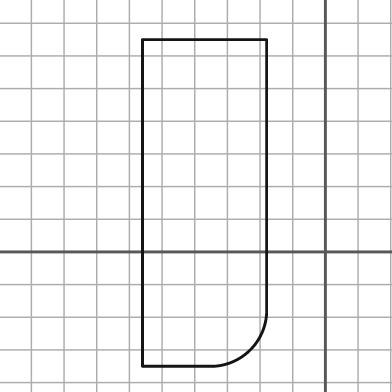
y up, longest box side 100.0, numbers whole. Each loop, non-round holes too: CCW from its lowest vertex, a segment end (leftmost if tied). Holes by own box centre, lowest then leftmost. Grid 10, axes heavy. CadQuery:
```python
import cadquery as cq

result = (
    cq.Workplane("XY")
    .moveTo(-56.0, -35.0)
    .lineTo(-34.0, -35.0)
    .threePointArc((-23.0, -30.0), (-18.0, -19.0))
    .lineTo(-18.0, 65.0)
    .lineTo(-56.0, 65.0)
    .close()
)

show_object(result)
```